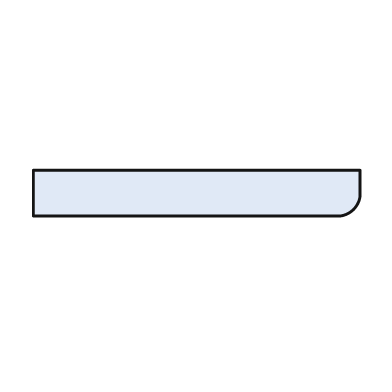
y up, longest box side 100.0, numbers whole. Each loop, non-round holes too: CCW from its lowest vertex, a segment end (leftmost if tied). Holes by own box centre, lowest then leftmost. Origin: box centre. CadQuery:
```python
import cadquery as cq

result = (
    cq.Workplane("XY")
    .moveTo(-50.0, -7.0)
    .lineTo(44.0, -7.0)
    .threePointArc((48.0, -5.0), (50.0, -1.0))
    .lineTo(50.0, 7.0)
    .lineTo(-50.0, 7.0)
    .close()
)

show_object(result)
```